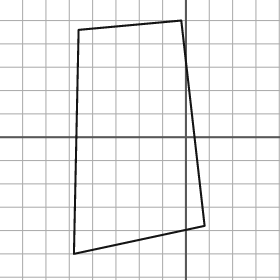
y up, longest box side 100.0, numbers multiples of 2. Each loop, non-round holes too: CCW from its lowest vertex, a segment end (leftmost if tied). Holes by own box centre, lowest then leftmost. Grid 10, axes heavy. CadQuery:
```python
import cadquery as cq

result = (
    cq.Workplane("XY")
    .moveTo(-48.0, -50.0)
    .lineTo(8.0, -38.0)
    .lineTo(-2.0, 50.0)
    .lineTo(-46.0, 46.0)
    .close()
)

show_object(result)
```